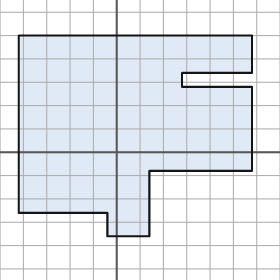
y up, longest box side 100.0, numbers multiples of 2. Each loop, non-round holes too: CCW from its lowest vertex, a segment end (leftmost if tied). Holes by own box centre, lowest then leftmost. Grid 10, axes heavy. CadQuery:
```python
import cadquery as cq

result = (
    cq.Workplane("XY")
    .moveTo(-4.0, -36.0)
    .lineTo(14.0, -36.0)
    .lineTo(14.0, -8.0)
    .lineTo(58.0, -8.0)
    .lineTo(58.0, 28.0)
    .lineTo(28.0, 28.0)
    .lineTo(28.0, 34.0)
    .lineTo(58.0, 34.0)
    .lineTo(58.0, 50.0)
    .lineTo(-42.0, 50.0)
    .lineTo(-42.0, -26.0)
    .lineTo(-4.0, -26.0)
    .close()
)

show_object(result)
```